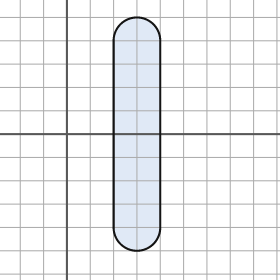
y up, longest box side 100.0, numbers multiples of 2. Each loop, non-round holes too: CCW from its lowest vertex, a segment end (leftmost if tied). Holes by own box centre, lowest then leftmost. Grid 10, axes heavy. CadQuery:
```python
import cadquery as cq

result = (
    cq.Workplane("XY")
    .moveTo(20.0, -40.0)
    .threePointArc((30.0, -50.0), (40.0, -40.0))
    .lineTo(40.0, 40.0)
    .threePointArc((30.0, 50.0), (20.0, 40.0))
    .close()
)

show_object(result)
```